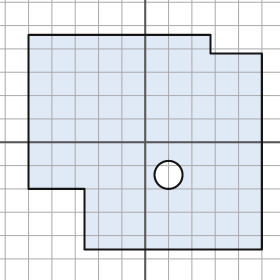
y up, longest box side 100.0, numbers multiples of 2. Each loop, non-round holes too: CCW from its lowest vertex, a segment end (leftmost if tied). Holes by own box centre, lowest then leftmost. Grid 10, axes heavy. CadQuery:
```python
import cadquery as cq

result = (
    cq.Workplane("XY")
    .moveTo(-26.0, -46.0)
    .lineTo(50.0, -46.0)
    .lineTo(50.0, 38.0)
    .lineTo(28.0, 38.0)
    .lineTo(28.0, 46.0)
    .lineTo(-50.0, 46.0)
    .lineTo(-50.0, -20.0)
    .lineTo(-26.0, -20.0)
    .close()
    .moveTo(10.0, -14.0)
    .circle(6.0)
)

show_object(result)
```